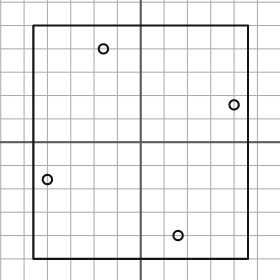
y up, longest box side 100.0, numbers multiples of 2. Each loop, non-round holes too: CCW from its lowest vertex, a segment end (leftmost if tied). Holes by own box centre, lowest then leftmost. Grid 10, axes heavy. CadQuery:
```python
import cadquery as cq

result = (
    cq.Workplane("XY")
    .moveTo(-46.0, -50.0)
    .lineTo(46.0, -50.0)
    .lineTo(46.0, 50.0)
    .lineTo(-46.0, 50.0)
    .close()
    .moveTo(16.0, -40.0)
    .circle(2.0)
    .moveTo(-40.0, -16.0)
    .circle(2.0)
    .moveTo(40.0, 16.0)
    .circle(2.0)
    .moveTo(-16.0, 40.0)
    .circle(2.0)
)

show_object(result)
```